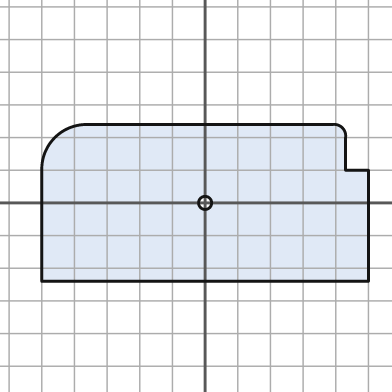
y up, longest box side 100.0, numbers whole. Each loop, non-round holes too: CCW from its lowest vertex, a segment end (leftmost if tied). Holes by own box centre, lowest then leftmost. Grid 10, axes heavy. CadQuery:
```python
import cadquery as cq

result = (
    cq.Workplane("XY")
    .moveTo(-50.0, -24.0)
    .lineTo(50.0, -24.0)
    .lineTo(50.0, 10.0)
    .lineTo(43.0, 10.0)
    .lineTo(43.0, 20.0)
    .threePointArc((42.0, 23.0), (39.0, 24.0))
    .lineTo(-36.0, 24.0)
    .threePointArc((-46.0, 20.0), (-50.0, 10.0))
    .close()
    .moveTo(0.0, 0.0)
    .circle(2.0)
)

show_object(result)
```